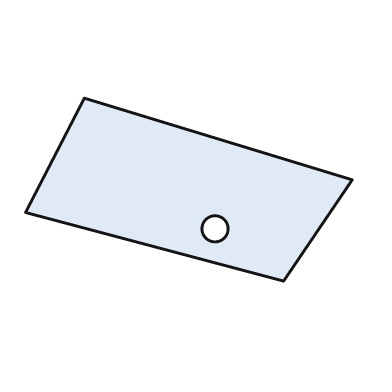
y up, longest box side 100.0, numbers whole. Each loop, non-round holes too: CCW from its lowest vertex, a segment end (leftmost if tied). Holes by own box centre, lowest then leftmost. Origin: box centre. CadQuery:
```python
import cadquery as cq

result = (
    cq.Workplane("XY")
    .moveTo(29.0, -28.0)
    .lineTo(50.0, 3.0)
    .lineTo(-32.0, 28.0)
    .lineTo(-50.0, -7.0)
    .close()
    .moveTo(8.0, -12.0)
    .circle(4.0)
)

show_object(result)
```